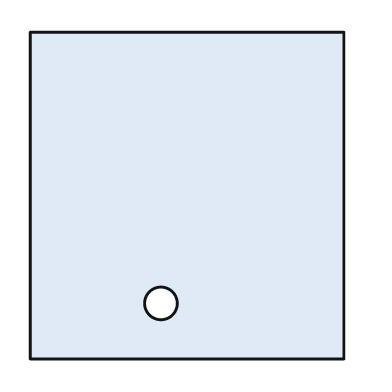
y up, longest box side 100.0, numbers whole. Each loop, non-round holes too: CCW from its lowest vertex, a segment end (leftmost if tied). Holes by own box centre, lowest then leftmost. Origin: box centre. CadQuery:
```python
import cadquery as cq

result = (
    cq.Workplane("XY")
    .moveTo(-48.0, -50.0)
    .lineTo(48.0, -50.0)
    .lineTo(48.0, 50.0)
    .lineTo(-48.0, 50.0)
    .close()
    .moveTo(-8.0, -33.0)
    .circle(5.0)
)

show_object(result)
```